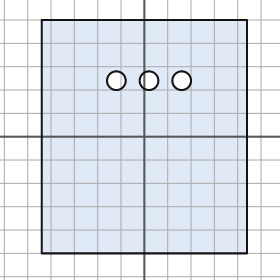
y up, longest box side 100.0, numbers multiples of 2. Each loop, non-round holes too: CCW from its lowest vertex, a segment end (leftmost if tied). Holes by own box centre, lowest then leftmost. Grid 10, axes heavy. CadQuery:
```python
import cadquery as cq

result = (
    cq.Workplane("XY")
    .moveTo(-44.0, -50.0)
    .lineTo(44.0, -50.0)
    .lineTo(44.0, 50.0)
    .lineTo(-44.0, 50.0)
    .close()
    .moveTo(-12.0, 24.0)
    .circle(4.0)
    .moveTo(2.0, 24.0)
    .circle(4.0)
    .moveTo(16.0, 24.0)
    .circle(4.0)
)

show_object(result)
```